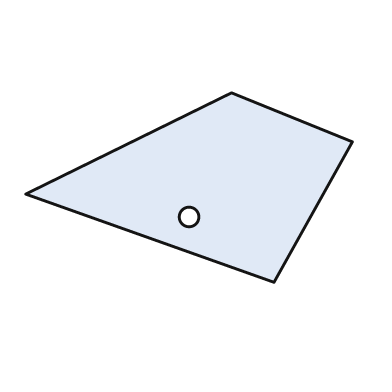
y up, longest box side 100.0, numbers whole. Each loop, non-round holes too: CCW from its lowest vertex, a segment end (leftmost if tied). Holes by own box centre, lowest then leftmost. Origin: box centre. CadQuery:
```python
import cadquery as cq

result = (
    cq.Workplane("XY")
    .moveTo(26.0, -29.0)
    .lineTo(50.0, 14.0)
    .lineTo(13.0, 29.0)
    .lineTo(-50.0, -2.0)
    .close()
    .moveTo(0.0, -9.0)
    .circle(3.0)
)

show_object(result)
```